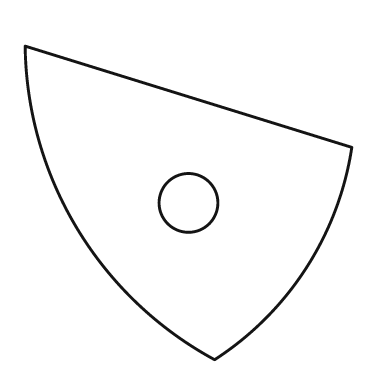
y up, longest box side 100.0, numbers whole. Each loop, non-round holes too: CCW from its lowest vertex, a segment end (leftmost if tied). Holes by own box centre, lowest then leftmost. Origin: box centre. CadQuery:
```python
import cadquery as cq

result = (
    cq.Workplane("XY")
    .moveTo(8.0, -48.0)
    .threePointArc((36.0, -20.0), (50.0, 17.0))
    .lineTo(-50.0, 48.0)
    .threePointArc((-34.0, -8.0), (8.0, -48.0))
    .close()
    .moveTo(0.0, 0.0)
    .circle(9.0)
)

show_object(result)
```